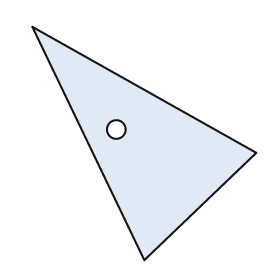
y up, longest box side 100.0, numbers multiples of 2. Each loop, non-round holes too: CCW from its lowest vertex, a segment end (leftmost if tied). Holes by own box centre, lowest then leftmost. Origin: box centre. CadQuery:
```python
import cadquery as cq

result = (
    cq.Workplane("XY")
    .moveTo(0.0, -50.0)
    .lineTo(48.0, -4.0)
    .lineTo(-48.0, 50.0)
    .close()
    .moveTo(-12.0, 6.0)
    .circle(4.0)
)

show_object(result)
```